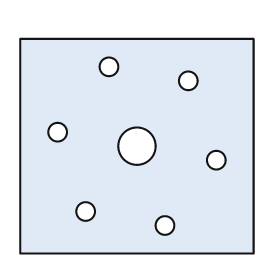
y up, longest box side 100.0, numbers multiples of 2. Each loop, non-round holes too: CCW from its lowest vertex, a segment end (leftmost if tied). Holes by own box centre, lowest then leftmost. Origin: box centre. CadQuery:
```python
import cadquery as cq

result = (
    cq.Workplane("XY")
    .moveTo(-50.0, -46.0)
    .lineTo(50.0, -46.0)
    .lineTo(50.0, 46.0)
    .lineTo(-50.0, 46.0)
    .close()
    .moveTo(12.0, -34.0)
    .circle(4.0)
    .moveTo(-22.0, -28.0)
    .circle(4.0)
    .moveTo(34.0, -6.0)
    .circle(4.0)
    .moveTo(0.0, 0.0)
    .circle(8.0)
    .moveTo(-34.0, 6.0)
    .circle(4.0)
    .moveTo(22.0, 28.0)
    .circle(4.0)
    .moveTo(-12.0, 34.0)
    .circle(4.0)
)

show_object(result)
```